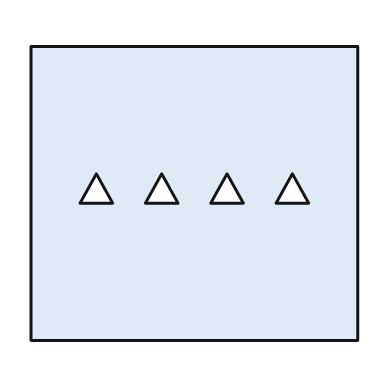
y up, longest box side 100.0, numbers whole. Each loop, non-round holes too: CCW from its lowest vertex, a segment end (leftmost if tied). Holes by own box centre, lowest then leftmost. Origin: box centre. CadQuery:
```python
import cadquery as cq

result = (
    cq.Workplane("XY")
    .moveTo(-50.0, -45.0)
    .lineTo(50.0, -45.0)
    .lineTo(50.0, 45.0)
    .lineTo(-50.0, 45.0)
    .close()
    .moveTo(-35.0, -3.0)
    .lineTo(-25.0, -3.0)
    .lineTo(-30.0, 6.0)
    .close()
    .moveTo(-15.0, -3.0)
    .lineTo(-5.0, -3.0)
    .lineTo(-10.0, 6.0)
    .close()
    .moveTo(5.0, -3.0)
    .lineTo(15.0, -3.0)
    .lineTo(10.0, 6.0)
    .close()
    .moveTo(25.0, -3.0)
    .lineTo(35.0, -3.0)
    .lineTo(30.0, 6.0)
    .close()
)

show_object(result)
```